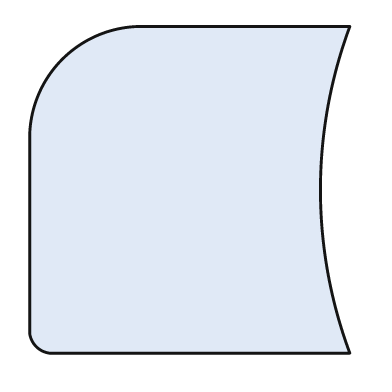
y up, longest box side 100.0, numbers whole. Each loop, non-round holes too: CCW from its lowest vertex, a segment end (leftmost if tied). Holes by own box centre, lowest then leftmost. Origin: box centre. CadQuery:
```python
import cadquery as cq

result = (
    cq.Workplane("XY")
    .moveTo(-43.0, -50.0)
    .lineTo(49.0, -50.0)
    .threePointArc((40.0, 0.0), (49.0, 50.0))
    .lineTo(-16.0, 50.0)
    .threePointArc((-39.0, 40.0), (-49.0, 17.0))
    .lineTo(-49.0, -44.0)
    .threePointArc((-47.0, -48.0), (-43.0, -50.0))
    .close()
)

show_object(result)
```